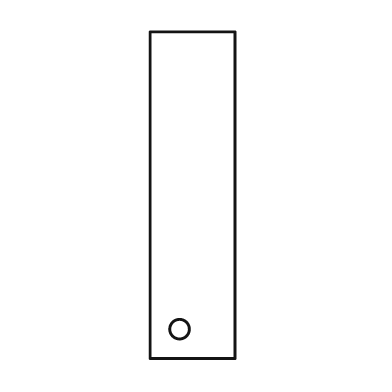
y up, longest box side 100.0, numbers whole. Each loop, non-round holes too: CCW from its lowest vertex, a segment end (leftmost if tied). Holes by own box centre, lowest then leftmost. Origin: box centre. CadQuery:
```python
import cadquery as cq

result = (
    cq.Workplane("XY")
    .moveTo(-13.0, -50.0)
    .lineTo(13.0, -50.0)
    .lineTo(13.0, 50.0)
    .lineTo(-13.0, 50.0)
    .close()
    .moveTo(-4.0, -41.0)
    .circle(3.0)
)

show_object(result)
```